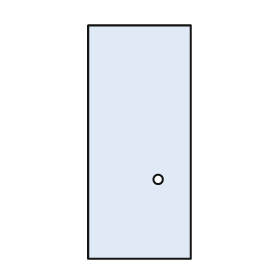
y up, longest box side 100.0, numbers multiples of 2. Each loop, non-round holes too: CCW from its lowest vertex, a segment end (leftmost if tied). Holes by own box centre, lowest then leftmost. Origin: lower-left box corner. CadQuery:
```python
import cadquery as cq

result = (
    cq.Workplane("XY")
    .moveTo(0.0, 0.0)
    .lineTo(44.0, 0.0)
    .lineTo(44.0, 100.0)
    .lineTo(0.0, 100.0)
    .close()
    .moveTo(30.0, 34.0)
    .circle(2.0)
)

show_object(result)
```